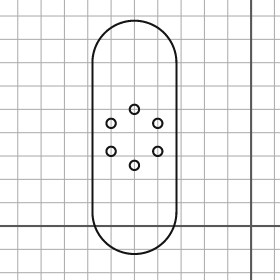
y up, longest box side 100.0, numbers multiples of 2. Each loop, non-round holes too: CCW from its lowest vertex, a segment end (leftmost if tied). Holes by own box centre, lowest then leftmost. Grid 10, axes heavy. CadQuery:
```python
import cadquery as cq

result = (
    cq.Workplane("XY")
    .moveTo(-68.0, 6.0)
    .threePointArc((-50.0, -12.0), (-32.0, 6.0))
    .lineTo(-32.0, 70.0)
    .threePointArc((-50.0, 88.0), (-68.0, 70.0))
    .close()
    .moveTo(-50.0, 26.0)
    .circle(2.0)
    .moveTo(-60.0, 32.0)
    .circle(2.0)
    .moveTo(-40.0, 32.0)
    .circle(2.0)
    .moveTo(-60.0, 44.0)
    .circle(2.0)
    .moveTo(-40.0, 44.0)
    .circle(2.0)
    .moveTo(-50.0, 50.0)
    .circle(2.0)
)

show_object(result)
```